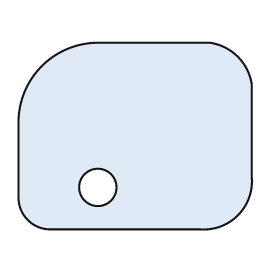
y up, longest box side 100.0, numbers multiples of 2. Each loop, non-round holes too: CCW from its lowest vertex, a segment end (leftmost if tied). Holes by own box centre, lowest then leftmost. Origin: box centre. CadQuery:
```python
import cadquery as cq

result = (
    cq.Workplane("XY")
    .moveTo(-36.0, -40.0)
    .lineTo(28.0, -40.0)
    .threePointArc((44.0, -34.0), (50.0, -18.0))
    .lineTo(50.0, 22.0)
    .threePointArc((44.0, 34.0), (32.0, 40.0))
    .lineTo(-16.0, 40.0)
    .threePointArc((-40.0, 30.0), (-50.0, 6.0))
    .lineTo(-50.0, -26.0)
    .threePointArc((-46.0, -36.0), (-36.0, -40.0))
    .close()
    .moveTo(-16.0, -22.0)
    .circle(8.0)
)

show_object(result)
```